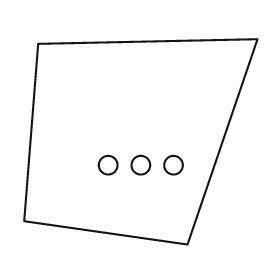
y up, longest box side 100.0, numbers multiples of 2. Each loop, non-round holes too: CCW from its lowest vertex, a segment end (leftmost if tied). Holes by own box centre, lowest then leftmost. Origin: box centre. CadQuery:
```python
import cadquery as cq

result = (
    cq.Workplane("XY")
    .moveTo(20.0, -44.0)
    .lineTo(50.0, 44.0)
    .lineTo(-44.0, 42.0)
    .lineTo(-50.0, -34.0)
    .close()
    .moveTo(-14.0, -10.0)
    .circle(4.0)
    .moveTo(0.0, -10.0)
    .circle(4.0)
    .moveTo(14.0, -10.0)
    .circle(4.0)
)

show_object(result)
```